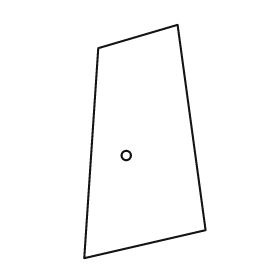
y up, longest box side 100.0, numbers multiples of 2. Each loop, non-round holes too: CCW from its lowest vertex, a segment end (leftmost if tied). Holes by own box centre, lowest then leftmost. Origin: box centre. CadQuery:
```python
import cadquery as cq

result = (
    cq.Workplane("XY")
    .moveTo(-26.0, -50.0)
    .lineTo(26.0, -38.0)
    .lineTo(14.0, 50.0)
    .lineTo(-20.0, 40.0)
    .close()
    .moveTo(-8.0, -6.0)
    .circle(2.0)
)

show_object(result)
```